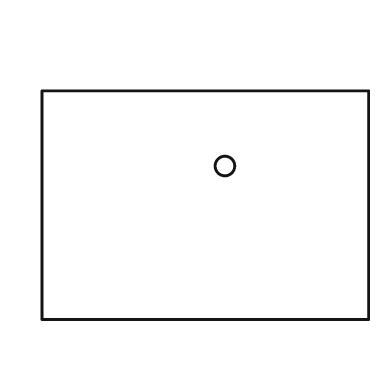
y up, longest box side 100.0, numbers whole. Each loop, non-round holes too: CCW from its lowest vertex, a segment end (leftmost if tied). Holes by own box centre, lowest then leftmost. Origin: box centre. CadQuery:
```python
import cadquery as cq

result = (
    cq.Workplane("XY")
    .moveTo(-50.0, -35.0)
    .lineTo(50.0, -35.0)
    .lineTo(50.0, 35.0)
    .lineTo(-50.0, 35.0)
    .close()
    .moveTo(6.0, 12.0)
    .circle(3.0)
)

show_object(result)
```